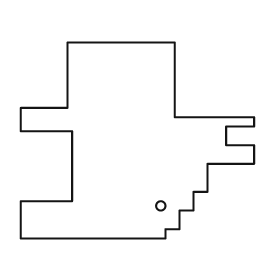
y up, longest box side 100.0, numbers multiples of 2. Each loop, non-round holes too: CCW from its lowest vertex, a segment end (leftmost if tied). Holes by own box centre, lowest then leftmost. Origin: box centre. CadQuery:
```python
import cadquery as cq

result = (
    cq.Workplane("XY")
    .moveTo(-50.0, -42.0)
    .lineTo(12.0, -42.0)
    .lineTo(12.0, -38.0)
    .lineTo(18.0, -38.0)
    .lineTo(18.0, -30.0)
    .lineTo(24.0, -30.0)
    .lineTo(24.0, -22.0)
    .lineTo(30.0, -22.0)
    .lineTo(30.0, -10.0)
    .lineTo(50.0, -10.0)
    .lineTo(50.0, -2.0)
    .lineTo(38.0, -2.0)
    .lineTo(38.0, 6.0)
    .lineTo(50.0, 6.0)
    .lineTo(50.0, 10.0)
    .lineTo(16.0, 10.0)
    .lineTo(16.0, 42.0)
    .lineTo(-30.0, 42.0)
    .lineTo(-30.0, 14.0)
    .lineTo(-50.0, 14.0)
    .lineTo(-50.0, 4.0)
    .lineTo(-28.0, 4.0)
    .lineTo(-28.0, -26.0)
    .lineTo(-50.0, -26.0)
    .close()
    .moveTo(10.0, -28.0)
    .circle(2.0)
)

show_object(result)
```